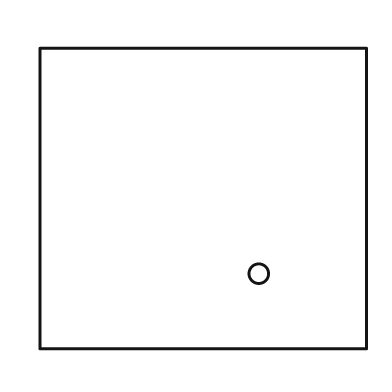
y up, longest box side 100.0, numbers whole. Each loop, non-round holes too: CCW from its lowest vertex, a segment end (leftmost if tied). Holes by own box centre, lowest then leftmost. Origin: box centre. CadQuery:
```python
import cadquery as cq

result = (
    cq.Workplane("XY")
    .moveTo(-50.0, -46.0)
    .lineTo(50.0, -46.0)
    .lineTo(50.0, 46.0)
    .lineTo(-50.0, 46.0)
    .close()
    .moveTo(17.0, -23.0)
    .circle(3.0)
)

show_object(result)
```